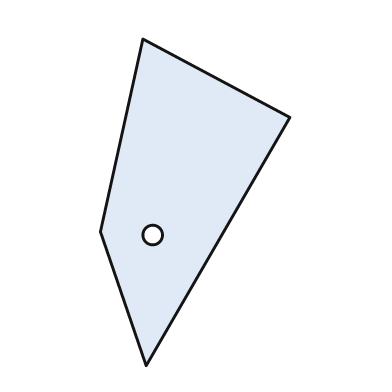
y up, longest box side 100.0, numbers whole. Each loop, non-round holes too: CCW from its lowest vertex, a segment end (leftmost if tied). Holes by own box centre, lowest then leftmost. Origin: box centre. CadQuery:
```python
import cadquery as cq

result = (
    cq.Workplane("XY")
    .moveTo(-15.0, -50.0)
    .lineTo(29.0, 26.0)
    .lineTo(-16.0, 50.0)
    .lineTo(-29.0, -9.0)
    .close()
    .moveTo(-13.0, -10.0)
    .circle(3.0)
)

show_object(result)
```